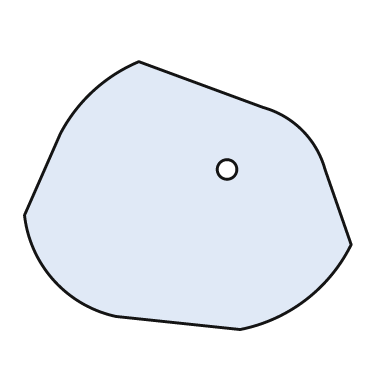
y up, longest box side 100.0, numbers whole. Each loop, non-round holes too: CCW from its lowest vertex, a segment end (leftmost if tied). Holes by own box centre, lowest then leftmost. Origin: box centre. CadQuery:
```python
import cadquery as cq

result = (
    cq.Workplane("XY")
    .moveTo(16.0, -41.0)
    .threePointArc((36.0, -32.0), (50.0, -15.0))
    .lineTo(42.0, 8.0)
    .threePointArc((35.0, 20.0), (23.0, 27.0))
    .lineTo(-15.0, 41.0)
    .threePointArc((-29.0, 32.0), (-39.0, 19.0))
    .lineTo(-50.0, -6.0)
    .threePointArc((-41.0, -26.0), (-22.0, -37.0))
    .close()
    .moveTo(12.0, 8.0)
    .circle(3.0)
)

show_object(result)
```